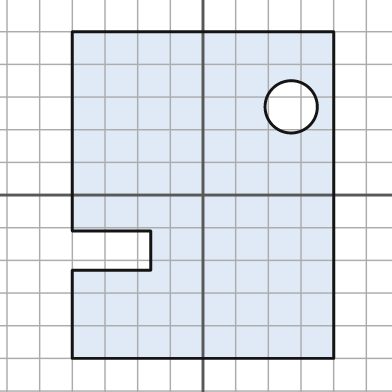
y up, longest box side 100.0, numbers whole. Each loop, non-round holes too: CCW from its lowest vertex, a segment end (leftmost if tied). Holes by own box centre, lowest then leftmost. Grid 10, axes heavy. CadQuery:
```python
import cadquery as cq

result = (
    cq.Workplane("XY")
    .moveTo(-40.0, -50.0)
    .lineTo(40.0, -50.0)
    .lineTo(40.0, 50.0)
    .lineTo(-40.0, 50.0)
    .lineTo(-40.0, -11.0)
    .lineTo(-16.0, -11.0)
    .lineTo(-16.0, -23.0)
    .lineTo(-40.0, -23.0)
    .close()
    .moveTo(27.0, 27.0)
    .circle(8.0)
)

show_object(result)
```